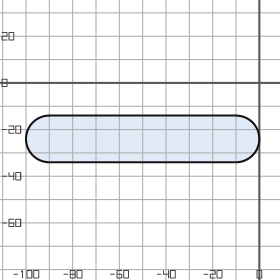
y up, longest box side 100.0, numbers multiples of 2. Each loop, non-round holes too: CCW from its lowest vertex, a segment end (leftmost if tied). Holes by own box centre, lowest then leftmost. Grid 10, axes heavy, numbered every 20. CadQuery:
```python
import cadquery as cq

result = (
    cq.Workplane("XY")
    .moveTo(-90.0, -34.0)
    .lineTo(-10.0, -34.0)
    .threePointArc((0.0, -24.0), (-10.0, -14.0))
    .lineTo(-90.0, -14.0)
    .threePointArc((-100.0, -24.0), (-90.0, -34.0))
    .close()
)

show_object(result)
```